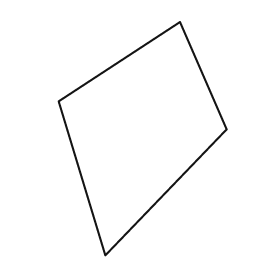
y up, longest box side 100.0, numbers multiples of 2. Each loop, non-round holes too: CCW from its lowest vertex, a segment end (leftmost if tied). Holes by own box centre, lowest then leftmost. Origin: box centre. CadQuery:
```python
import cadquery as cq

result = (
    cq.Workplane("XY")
    .moveTo(-16.0, -50.0)
    .lineTo(36.0, 4.0)
    .lineTo(16.0, 50.0)
    .lineTo(-36.0, 16.0)
    .close()
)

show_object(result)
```